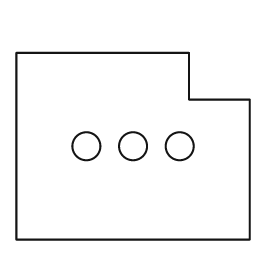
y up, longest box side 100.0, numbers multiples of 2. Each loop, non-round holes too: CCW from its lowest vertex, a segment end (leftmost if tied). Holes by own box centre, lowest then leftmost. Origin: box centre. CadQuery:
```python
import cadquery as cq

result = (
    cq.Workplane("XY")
    .moveTo(-50.0, -40.0)
    .lineTo(50.0, -40.0)
    .lineTo(50.0, 20.0)
    .lineTo(24.0, 20.0)
    .lineTo(24.0, 40.0)
    .lineTo(-50.0, 40.0)
    .close()
    .moveTo(-20.0, 0.0)
    .circle(6.0)
    .moveTo(0.0, 0.0)
    .circle(6.0)
    .moveTo(20.0, 0.0)
    .circle(6.0)
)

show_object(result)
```